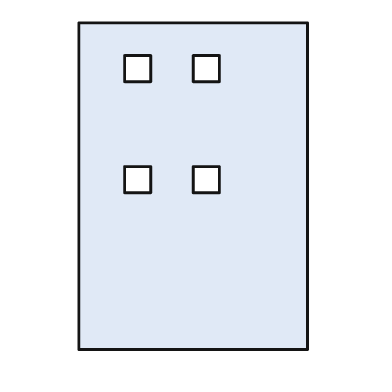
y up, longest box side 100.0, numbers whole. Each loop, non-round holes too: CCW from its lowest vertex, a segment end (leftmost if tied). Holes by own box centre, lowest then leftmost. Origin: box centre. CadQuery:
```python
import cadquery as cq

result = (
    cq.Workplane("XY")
    .moveTo(-35.0, -50.0)
    .lineTo(35.0, -50.0)
    .lineTo(35.0, 50.0)
    .lineTo(-35.0, 50.0)
    .close()
    .moveTo(-21.0, -2.0)
    .lineTo(-13.0, -2.0)
    .lineTo(-13.0, 6.0)
    .lineTo(-21.0, 6.0)
    .close()
    .moveTo(0.0, -2.0)
    .lineTo(8.0, -2.0)
    .lineTo(8.0, 6.0)
    .lineTo(0.0, 6.0)
    .close()
    .moveTo(-21.0, 32.0)
    .lineTo(-13.0, 32.0)
    .lineTo(-13.0, 40.0)
    .lineTo(-21.0, 40.0)
    .close()
    .moveTo(0.0, 32.0)
    .lineTo(8.0, 32.0)
    .lineTo(8.0, 40.0)
    .lineTo(0.0, 40.0)
    .close()
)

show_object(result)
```